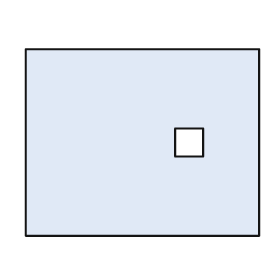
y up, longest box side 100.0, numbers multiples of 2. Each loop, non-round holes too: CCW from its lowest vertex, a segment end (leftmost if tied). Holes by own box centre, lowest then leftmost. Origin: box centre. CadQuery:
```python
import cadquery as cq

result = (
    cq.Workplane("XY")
    .moveTo(-50.0, -40.0)
    .lineTo(50.0, -40.0)
    .lineTo(50.0, 40.0)
    .lineTo(-50.0, 40.0)
    .close()
    .moveTo(14.0, -6.0)
    .lineTo(26.0, -6.0)
    .lineTo(26.0, 6.0)
    .lineTo(14.0, 6.0)
    .close()
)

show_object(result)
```